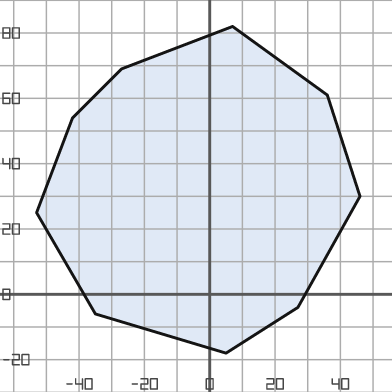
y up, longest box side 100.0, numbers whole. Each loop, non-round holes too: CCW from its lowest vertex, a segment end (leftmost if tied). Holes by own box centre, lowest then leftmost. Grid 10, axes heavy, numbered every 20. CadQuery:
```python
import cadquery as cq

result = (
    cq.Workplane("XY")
    .moveTo(5.0, -18.0)
    .lineTo(27.0, -4.0)
    .lineTo(46.0, 30.0)
    .lineTo(36.0, 61.0)
    .lineTo(7.0, 82.0)
    .lineTo(-27.0, 69.0)
    .lineTo(-42.0, 54.0)
    .lineTo(-53.0, 25.0)
    .lineTo(-35.0, -6.0)
    .close()
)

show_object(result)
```